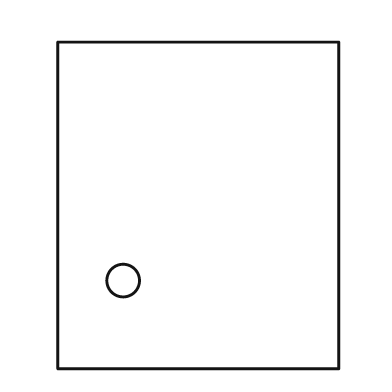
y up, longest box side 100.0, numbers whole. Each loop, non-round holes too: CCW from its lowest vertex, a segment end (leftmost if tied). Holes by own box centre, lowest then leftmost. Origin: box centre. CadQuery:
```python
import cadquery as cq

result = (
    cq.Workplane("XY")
    .moveTo(-43.0, -50.0)
    .lineTo(43.0, -50.0)
    .lineTo(43.0, 50.0)
    .lineTo(-43.0, 50.0)
    .close()
    .moveTo(-23.0, -23.0)
    .circle(5.0)
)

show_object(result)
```